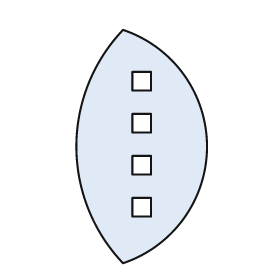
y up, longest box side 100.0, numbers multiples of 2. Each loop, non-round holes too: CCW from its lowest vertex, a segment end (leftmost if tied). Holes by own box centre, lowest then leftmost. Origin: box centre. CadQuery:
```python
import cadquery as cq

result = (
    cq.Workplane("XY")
    .moveTo(-8.0, -50.0)
    .threePointArc((28.0, 0.0), (-8.0, 50.0))
    .threePointArc((-28.0, 0.0), (-8.0, -50.0))
    .close()
    .moveTo(-4.0, -30.0)
    .lineTo(4.0, -30.0)
    .lineTo(4.0, -22.0)
    .lineTo(-4.0, -22.0)
    .close()
    .moveTo(-4.0, -12.0)
    .lineTo(4.0, -12.0)
    .lineTo(4.0, -4.0)
    .lineTo(-4.0, -4.0)
    .close()
    .moveTo(-4.0, 6.0)
    .lineTo(4.0, 6.0)
    .lineTo(4.0, 14.0)
    .lineTo(-4.0, 14.0)
    .close()
    .moveTo(-4.0, 24.0)
    .lineTo(4.0, 24.0)
    .lineTo(4.0, 32.0)
    .lineTo(-4.0, 32.0)
    .close()
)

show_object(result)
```